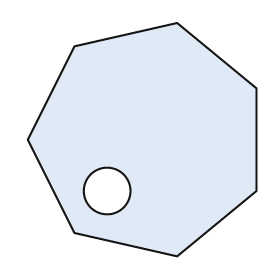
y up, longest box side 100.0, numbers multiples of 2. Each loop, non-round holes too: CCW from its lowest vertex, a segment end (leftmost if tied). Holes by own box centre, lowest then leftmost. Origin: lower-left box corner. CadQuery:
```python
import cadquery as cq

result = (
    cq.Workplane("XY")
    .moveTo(64.0, 0.0)
    .lineTo(98.0, 28.0)
    .lineTo(98.0, 72.0)
    .lineTo(64.0, 100.0)
    .lineTo(20.0, 90.0)
    .lineTo(0.0, 50.0)
    .lineTo(20.0, 10.0)
    .close()
    .moveTo(34.0, 28.0)
    .circle(10.0)
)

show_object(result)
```